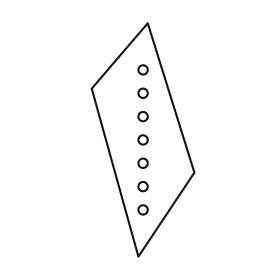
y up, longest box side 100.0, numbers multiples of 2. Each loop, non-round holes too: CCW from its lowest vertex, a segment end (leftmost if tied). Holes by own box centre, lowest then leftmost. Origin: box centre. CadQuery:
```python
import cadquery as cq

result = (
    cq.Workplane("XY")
    .moveTo(-2.0, -50.0)
    .lineTo(22.0, -14.0)
    .lineTo(2.0, 50.0)
    .lineTo(-22.0, 22.0)
    .close()
    .moveTo(0.0, -30.0)
    .circle(2.0)
    .moveTo(0.0, -20.0)
    .circle(2.0)
    .moveTo(0.0, -10.0)
    .circle(2.0)
    .moveTo(0.0, 0.0)
    .circle(2.0)
    .moveTo(0.0, 10.0)
    .circle(2.0)
    .moveTo(0.0, 20.0)
    .circle(2.0)
    .moveTo(0.0, 30.0)
    .circle(2.0)
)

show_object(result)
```